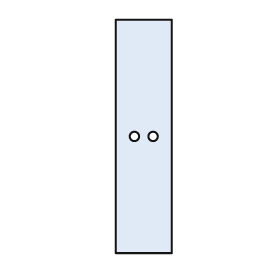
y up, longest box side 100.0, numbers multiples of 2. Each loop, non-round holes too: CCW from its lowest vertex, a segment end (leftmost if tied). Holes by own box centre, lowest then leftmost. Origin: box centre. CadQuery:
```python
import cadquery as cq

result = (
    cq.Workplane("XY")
    .moveTo(-12.0, -50.0)
    .lineTo(12.0, -50.0)
    .lineTo(12.0, 50.0)
    .lineTo(-12.0, 50.0)
    .close()
    .moveTo(-4.0, 0.0)
    .circle(2.0)
    .moveTo(4.0, 0.0)
    .circle(2.0)
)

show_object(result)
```